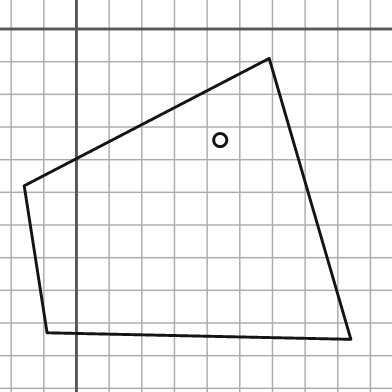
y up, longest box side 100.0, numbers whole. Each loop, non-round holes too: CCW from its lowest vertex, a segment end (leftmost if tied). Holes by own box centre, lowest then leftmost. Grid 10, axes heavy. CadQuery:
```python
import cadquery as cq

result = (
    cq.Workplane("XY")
    .moveTo(84.0, -95.0)
    .lineTo(59.0, -9.0)
    .lineTo(-16.0, -48.0)
    .lineTo(-9.0, -93.0)
    .close()
    .moveTo(44.0, -34.0)
    .circle(2.0)
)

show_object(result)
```